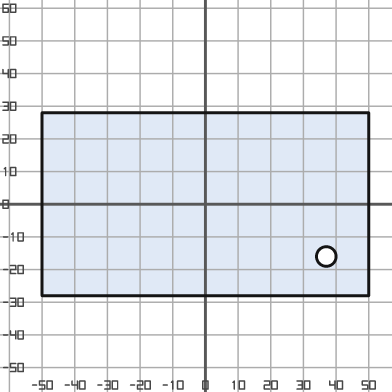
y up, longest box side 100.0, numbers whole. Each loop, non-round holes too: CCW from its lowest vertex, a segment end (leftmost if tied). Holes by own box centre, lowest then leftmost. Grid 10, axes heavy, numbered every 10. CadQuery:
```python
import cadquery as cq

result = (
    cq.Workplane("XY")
    .moveTo(-50.0, -28.0)
    .lineTo(50.0, -28.0)
    .lineTo(50.0, 28.0)
    .lineTo(-50.0, 28.0)
    .close()
    .moveTo(37.0, -16.0)
    .circle(3.0)
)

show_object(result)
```